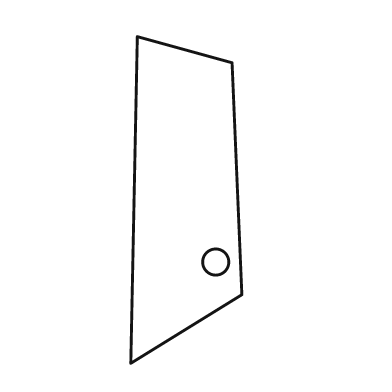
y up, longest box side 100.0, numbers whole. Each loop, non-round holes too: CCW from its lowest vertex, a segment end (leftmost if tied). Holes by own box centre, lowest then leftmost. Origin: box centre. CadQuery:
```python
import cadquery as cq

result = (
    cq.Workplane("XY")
    .moveTo(-17.0, -50.0)
    .lineTo(17.0, -29.0)
    .lineTo(14.0, 42.0)
    .lineTo(-15.0, 50.0)
    .close()
    .moveTo(9.0, -19.0)
    .circle(4.0)
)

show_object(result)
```